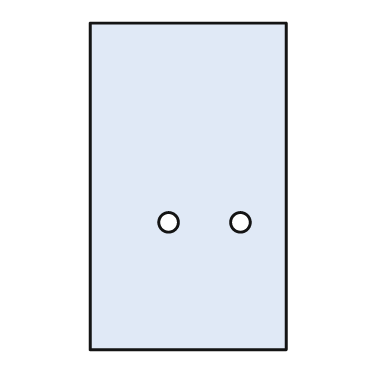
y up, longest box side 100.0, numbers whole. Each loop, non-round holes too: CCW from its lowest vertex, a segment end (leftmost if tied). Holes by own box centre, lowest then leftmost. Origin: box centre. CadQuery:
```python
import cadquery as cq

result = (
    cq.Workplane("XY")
    .moveTo(-30.0, -50.0)
    .lineTo(30.0, -50.0)
    .lineTo(30.0, 50.0)
    .lineTo(-30.0, 50.0)
    .close()
    .moveTo(-6.0, -11.0)
    .circle(3.0)
    .moveTo(16.0, -11.0)
    .circle(3.0)
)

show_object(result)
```